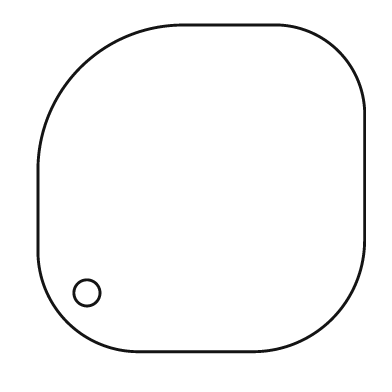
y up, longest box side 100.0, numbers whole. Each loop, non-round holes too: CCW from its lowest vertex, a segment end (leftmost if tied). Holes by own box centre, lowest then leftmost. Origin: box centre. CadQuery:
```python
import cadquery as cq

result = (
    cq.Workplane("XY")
    .moveTo(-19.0, -50.0)
    .lineTo(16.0, -50.0)
    .threePointArc((40.0, -40.0), (50.0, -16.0))
    .lineTo(50.0, 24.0)
    .threePointArc((42.0, 42.0), (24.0, 50.0))
    .lineTo(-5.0, 50.0)
    .threePointArc((-37.0, 37.0), (-50.0, 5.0))
    .lineTo(-50.0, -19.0)
    .threePointArc((-41.0, -41.0), (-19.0, -50.0))
    .close()
    .moveTo(-35.0, -32.0)
    .circle(4.0)
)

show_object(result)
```